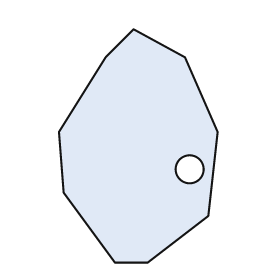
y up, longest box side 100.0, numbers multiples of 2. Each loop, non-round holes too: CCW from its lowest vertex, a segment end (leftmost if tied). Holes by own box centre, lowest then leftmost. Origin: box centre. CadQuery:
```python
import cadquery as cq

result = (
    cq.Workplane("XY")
    .moveTo(-10.0, -50.0)
    .lineTo(4.0, -50.0)
    .lineTo(30.0, -30.0)
    .lineTo(34.0, 6.0)
    .lineTo(20.0, 38.0)
    .lineTo(-2.0, 50.0)
    .lineTo(-14.0, 38.0)
    .lineTo(-34.0, 6.0)
    .lineTo(-32.0, -20.0)
    .close()
    .moveTo(22.0, -10.0)
    .circle(6.0)
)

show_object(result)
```